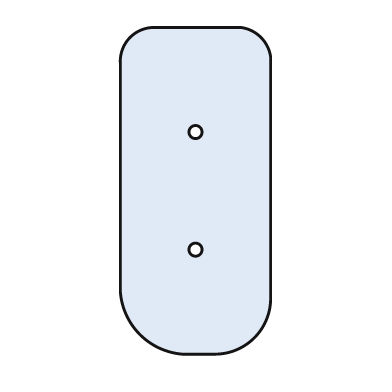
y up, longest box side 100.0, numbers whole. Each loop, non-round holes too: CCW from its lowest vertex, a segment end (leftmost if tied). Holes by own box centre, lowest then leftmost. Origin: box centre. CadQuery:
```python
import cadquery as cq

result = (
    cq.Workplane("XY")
    .moveTo(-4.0, -50.0)
    .lineTo(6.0, -50.0)
    .threePointArc((18.0, -45.0), (23.0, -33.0))
    .lineTo(23.0, 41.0)
    .threePointArc((20.0, 47.0), (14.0, 50.0))
    .lineTo(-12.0, 50.0)
    .threePointArc((-20.0, 47.0), (-23.0, 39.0))
    .lineTo(-23.0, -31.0)
    .threePointArc((-17.0, -44.0), (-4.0, -50.0))
    .close()
    .moveTo(0.0, -18.0)
    .circle(2.0)
    .moveTo(0.0, 18.0)
    .circle(2.0)
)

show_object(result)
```